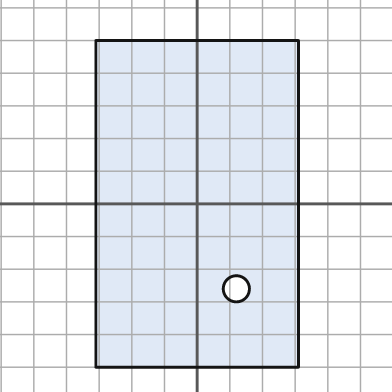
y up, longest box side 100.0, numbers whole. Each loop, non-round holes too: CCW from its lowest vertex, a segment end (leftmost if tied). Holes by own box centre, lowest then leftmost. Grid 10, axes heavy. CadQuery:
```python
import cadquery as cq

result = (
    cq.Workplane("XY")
    .moveTo(-31.0, -50.0)
    .lineTo(31.0, -50.0)
    .lineTo(31.0, 50.0)
    .lineTo(-31.0, 50.0)
    .close()
    .moveTo(12.0, -26.0)
    .circle(4.0)
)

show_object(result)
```